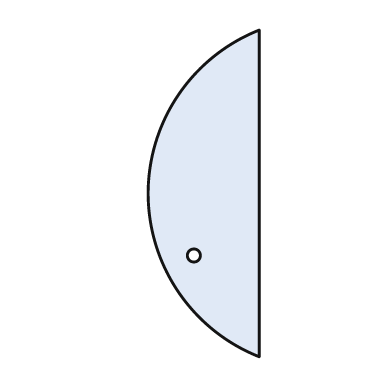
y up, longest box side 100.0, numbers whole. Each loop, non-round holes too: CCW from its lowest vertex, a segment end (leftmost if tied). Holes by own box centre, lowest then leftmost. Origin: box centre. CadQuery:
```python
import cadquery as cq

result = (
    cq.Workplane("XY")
    .moveTo(17.0, -50.0)
    .lineTo(17.0, 50.0)
    .threePointArc((-17.0, 0.0), (17.0, -50.0))
    .close()
    .moveTo(-3.0, -19.0)
    .circle(2.0)
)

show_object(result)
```